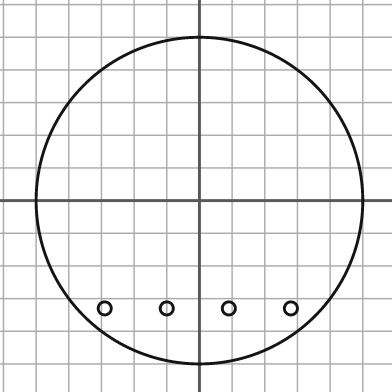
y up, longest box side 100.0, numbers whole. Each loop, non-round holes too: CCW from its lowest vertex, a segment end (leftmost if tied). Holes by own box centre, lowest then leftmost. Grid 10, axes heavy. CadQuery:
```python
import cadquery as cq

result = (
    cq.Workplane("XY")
    .moveTo(0.0, 0.0)
    .circle(50.0)
    .moveTo(-29.0, -33.0)
    .circle(2.0)
    .moveTo(-10.0, -33.0)
    .circle(2.0)
    .moveTo(9.0, -33.0)
    .circle(2.0)
    .moveTo(28.0, -33.0)
    .circle(2.0)
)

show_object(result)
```